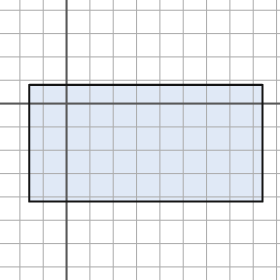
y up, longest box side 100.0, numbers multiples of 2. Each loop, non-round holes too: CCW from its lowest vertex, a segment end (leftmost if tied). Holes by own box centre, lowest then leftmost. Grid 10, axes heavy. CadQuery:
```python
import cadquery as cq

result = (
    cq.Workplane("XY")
    .moveTo(-16.0, -42.0)
    .lineTo(84.0, -42.0)
    .lineTo(84.0, 8.0)
    .lineTo(-16.0, 8.0)
    .close()
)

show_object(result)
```